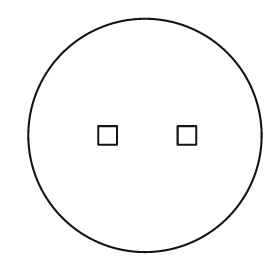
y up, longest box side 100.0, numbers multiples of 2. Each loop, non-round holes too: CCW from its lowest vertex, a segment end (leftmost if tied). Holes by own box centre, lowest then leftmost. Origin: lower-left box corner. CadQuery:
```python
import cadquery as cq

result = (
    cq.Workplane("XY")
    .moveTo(50.0, 50.0)
    .circle(50.0)
    .moveTo(30.0, 46.0)
    .lineTo(38.0, 46.0)
    .lineTo(38.0, 54.0)
    .lineTo(30.0, 54.0)
    .close()
    .moveTo(64.0, 46.0)
    .lineTo(72.0, 46.0)
    .lineTo(72.0, 54.0)
    .lineTo(64.0, 54.0)
    .close()
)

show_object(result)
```